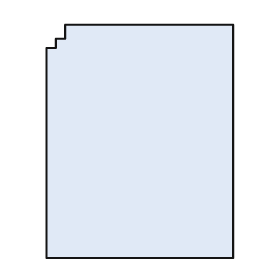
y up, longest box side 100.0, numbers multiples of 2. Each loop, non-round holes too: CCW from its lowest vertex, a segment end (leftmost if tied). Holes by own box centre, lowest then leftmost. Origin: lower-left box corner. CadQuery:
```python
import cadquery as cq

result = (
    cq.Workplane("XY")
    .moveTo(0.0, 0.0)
    .lineTo(80.0, 0.0)
    .lineTo(80.0, 100.0)
    .lineTo(8.0, 100.0)
    .lineTo(8.0, 94.0)
    .lineTo(4.0, 94.0)
    .lineTo(4.0, 90.0)
    .lineTo(0.0, 90.0)
    .close()
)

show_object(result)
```